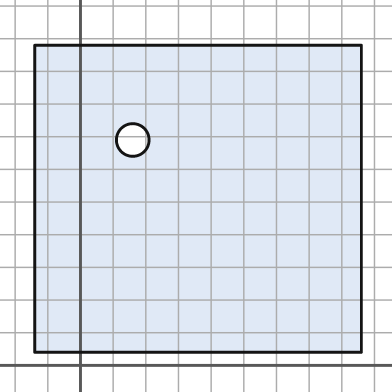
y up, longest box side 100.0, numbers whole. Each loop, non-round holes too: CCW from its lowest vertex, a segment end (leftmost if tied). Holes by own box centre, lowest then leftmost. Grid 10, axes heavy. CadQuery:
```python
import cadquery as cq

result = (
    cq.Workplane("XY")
    .moveTo(-14.0, 4.0)
    .lineTo(86.0, 4.0)
    .lineTo(86.0, 98.0)
    .lineTo(-14.0, 98.0)
    .close()
    .moveTo(16.0, 69.0)
    .circle(5.0)
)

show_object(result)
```